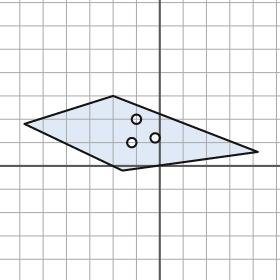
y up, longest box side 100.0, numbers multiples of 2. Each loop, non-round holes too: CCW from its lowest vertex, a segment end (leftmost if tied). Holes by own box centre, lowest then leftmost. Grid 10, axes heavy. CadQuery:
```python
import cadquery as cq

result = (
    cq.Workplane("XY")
    .moveTo(-16.0, -2.0)
    .lineTo(42.0, 6.0)
    .lineTo(-20.0, 30.0)
    .lineTo(-58.0, 18.0)
    .close()
    .moveTo(-12.0, 10.0)
    .circle(2.0)
    .moveTo(-2.0, 12.0)
    .circle(2.0)
    .moveTo(-10.0, 20.0)
    .circle(2.0)
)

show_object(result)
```